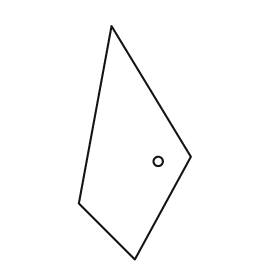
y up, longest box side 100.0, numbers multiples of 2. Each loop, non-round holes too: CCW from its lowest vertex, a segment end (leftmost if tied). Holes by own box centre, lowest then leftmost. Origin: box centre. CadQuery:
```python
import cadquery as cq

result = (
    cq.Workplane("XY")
    .moveTo(0.0, -50.0)
    .lineTo(24.0, -6.0)
    .lineTo(-10.0, 50.0)
    .lineTo(-24.0, -26.0)
    .close()
    .moveTo(10.0, -8.0)
    .circle(2.0)
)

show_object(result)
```